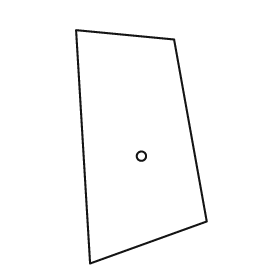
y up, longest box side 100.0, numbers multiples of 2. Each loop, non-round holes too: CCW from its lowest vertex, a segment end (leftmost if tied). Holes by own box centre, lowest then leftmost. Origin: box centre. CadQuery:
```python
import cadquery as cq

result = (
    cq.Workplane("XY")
    .moveTo(-22.0, -50.0)
    .lineTo(28.0, -32.0)
    .lineTo(14.0, 46.0)
    .lineTo(-28.0, 50.0)
    .close()
    .moveTo(0.0, -4.0)
    .circle(2.0)
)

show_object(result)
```